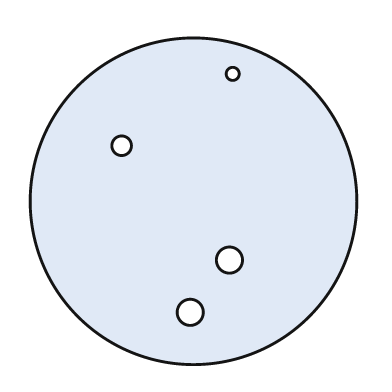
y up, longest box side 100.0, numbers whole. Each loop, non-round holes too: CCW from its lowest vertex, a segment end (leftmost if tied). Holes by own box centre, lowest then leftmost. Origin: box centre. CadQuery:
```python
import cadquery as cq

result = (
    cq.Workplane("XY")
    .moveTo(0.0, 0.0)
    .circle(50.0)
    .moveTo(-1.0, -34.0)
    .circle(4.0)
    .moveTo(11.0, -18.0)
    .circle(4.0)
    .moveTo(-22.0, 17.0)
    .circle(3.0)
    .moveTo(12.0, 39.0)
    .circle(2.0)
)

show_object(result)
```